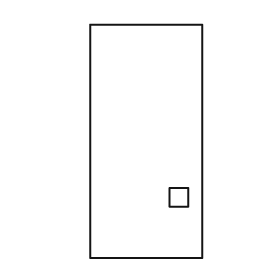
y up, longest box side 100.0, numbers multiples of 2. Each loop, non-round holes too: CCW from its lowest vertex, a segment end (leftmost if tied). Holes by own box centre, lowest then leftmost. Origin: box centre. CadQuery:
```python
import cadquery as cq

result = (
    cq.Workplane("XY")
    .moveTo(-24.0, -50.0)
    .lineTo(24.0, -50.0)
    .lineTo(24.0, 50.0)
    .lineTo(-24.0, 50.0)
    .close()
    .moveTo(10.0, -28.0)
    .lineTo(18.0, -28.0)
    .lineTo(18.0, -20.0)
    .lineTo(10.0, -20.0)
    .close()
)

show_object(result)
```